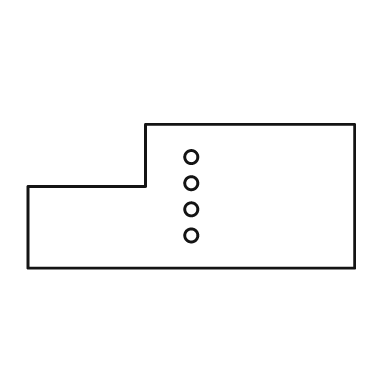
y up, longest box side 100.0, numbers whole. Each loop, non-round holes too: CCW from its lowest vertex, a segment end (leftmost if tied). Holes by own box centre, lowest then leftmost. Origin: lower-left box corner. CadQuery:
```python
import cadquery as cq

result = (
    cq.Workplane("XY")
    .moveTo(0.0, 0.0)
    .lineTo(100.0, 0.0)
    .lineTo(100.0, 44.0)
    .lineTo(36.0, 44.0)
    .lineTo(36.0, 25.0)
    .lineTo(0.0, 25.0)
    .close()
    .moveTo(50.0, 10.0)
    .circle(2.0)
    .moveTo(50.0, 18.0)
    .circle(2.0)
    .moveTo(50.0, 26.0)
    .circle(2.0)
    .moveTo(50.0, 34.0)
    .circle(2.0)
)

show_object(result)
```